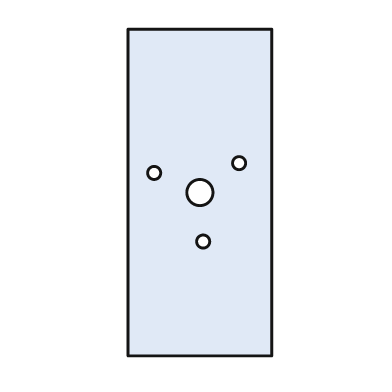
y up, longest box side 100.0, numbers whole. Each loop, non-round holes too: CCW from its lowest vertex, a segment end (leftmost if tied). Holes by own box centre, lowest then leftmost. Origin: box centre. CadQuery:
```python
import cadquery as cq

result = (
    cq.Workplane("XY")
    .moveTo(-22.0, -50.0)
    .lineTo(22.0, -50.0)
    .lineTo(22.0, 50.0)
    .lineTo(-22.0, 50.0)
    .close()
    .moveTo(1.0, -15.0)
    .circle(2.0)
    .moveTo(0.0, 0.0)
    .circle(4.0)
    .moveTo(-14.0, 6.0)
    .circle(2.0)
    .moveTo(12.0, 9.0)
    .circle(2.0)
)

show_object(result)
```